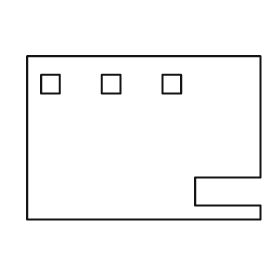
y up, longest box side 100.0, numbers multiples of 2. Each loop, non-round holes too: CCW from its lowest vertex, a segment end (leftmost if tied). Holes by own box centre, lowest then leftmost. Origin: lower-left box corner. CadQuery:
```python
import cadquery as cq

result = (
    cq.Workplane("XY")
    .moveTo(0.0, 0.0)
    .lineTo(100.0, 0.0)
    .lineTo(100.0, 6.0)
    .lineTo(72.0, 6.0)
    .lineTo(72.0, 18.0)
    .lineTo(100.0, 18.0)
    .lineTo(100.0, 70.0)
    .lineTo(0.0, 70.0)
    .close()
    .moveTo(6.0, 54.0)
    .lineTo(14.0, 54.0)
    .lineTo(14.0, 62.0)
    .lineTo(6.0, 62.0)
    .close()
    .moveTo(32.0, 54.0)
    .lineTo(40.0, 54.0)
    .lineTo(40.0, 62.0)
    .lineTo(32.0, 62.0)
    .close()
    .moveTo(58.0, 54.0)
    .lineTo(66.0, 54.0)
    .lineTo(66.0, 62.0)
    .lineTo(58.0, 62.0)
    .close()
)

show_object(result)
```